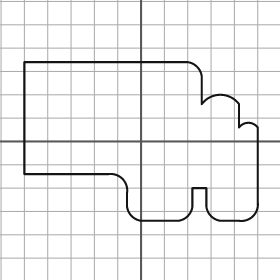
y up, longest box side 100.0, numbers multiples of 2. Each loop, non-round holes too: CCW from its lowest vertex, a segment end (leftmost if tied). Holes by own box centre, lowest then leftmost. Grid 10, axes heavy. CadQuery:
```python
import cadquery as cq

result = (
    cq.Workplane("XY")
    .moveTo(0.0, -34.0)
    .lineTo(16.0, -34.0)
    .threePointArc((20.0, -32.0), (22.0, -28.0))
    .lineTo(22.0, -20.0)
    .lineTo(28.0, -20.0)
    .lineTo(28.0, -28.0)
    .threePointArc((30.0, -32.0), (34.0, -34.0))
    .lineTo(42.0, -34.0)
    .threePointArc((48.0, -32.0), (50.0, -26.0))
    .lineTo(50.0, 6.0)
    .threePointArc((46.0, 8.0), (42.0, 6.0))
    .lineTo(42.0, 16.0)
    .threePointArc((34.0, 20.0), (26.0, 16.0))
    .lineTo(26.0, 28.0)
    .threePointArc((24.0, 32.0), (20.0, 34.0))
    .lineTo(-50.0, 34.0)
    .lineTo(-50.0, -14.0)
    .lineTo(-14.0, -14.0)
    .threePointArc((-8.0, -16.0), (-6.0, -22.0))
    .lineTo(-6.0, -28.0)
    .threePointArc((-4.0, -32.0), (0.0, -34.0))
    .close()
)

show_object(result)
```